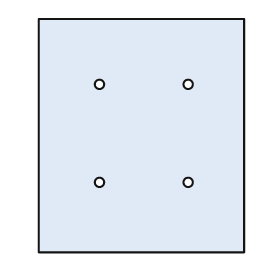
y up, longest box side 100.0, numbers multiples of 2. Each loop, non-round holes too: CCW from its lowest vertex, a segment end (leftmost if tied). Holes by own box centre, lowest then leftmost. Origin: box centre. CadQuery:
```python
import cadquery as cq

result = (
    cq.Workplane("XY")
    .moveTo(-44.0, -50.0)
    .lineTo(44.0, -50.0)
    .lineTo(44.0, 50.0)
    .lineTo(-44.0, 50.0)
    .close()
    .moveTo(-18.0, -20.0)
    .circle(2.0)
    .moveTo(20.0, -20.0)
    .circle(2.0)
    .moveTo(-18.0, 22.0)
    .circle(2.0)
    .moveTo(20.0, 22.0)
    .circle(2.0)
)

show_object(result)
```